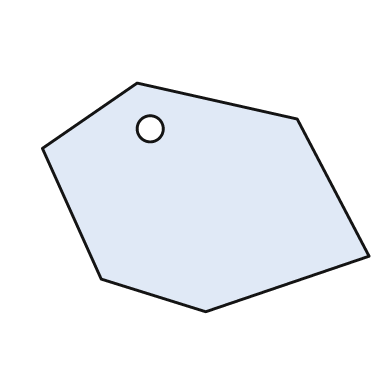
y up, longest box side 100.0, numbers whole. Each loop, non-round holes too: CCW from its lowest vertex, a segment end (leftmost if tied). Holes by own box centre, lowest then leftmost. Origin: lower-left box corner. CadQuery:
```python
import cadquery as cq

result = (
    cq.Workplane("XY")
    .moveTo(50.0, 0.0)
    .lineTo(100.0, 17.0)
    .lineTo(78.0, 59.0)
    .lineTo(29.0, 70.0)
    .lineTo(0.0, 50.0)
    .lineTo(18.0, 10.0)
    .close()
    .moveTo(33.0, 56.0)
    .circle(4.0)
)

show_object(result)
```